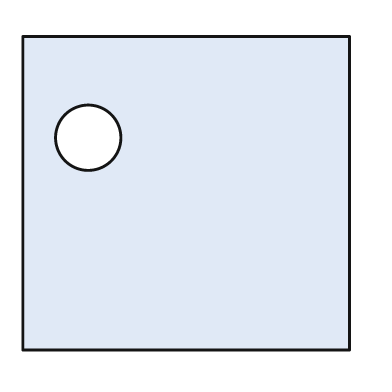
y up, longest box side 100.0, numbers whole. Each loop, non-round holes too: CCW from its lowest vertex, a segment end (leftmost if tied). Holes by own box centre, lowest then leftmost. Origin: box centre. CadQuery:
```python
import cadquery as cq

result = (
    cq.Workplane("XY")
    .moveTo(-50.0, -48.0)
    .lineTo(50.0, -48.0)
    .lineTo(50.0, 48.0)
    .lineTo(-50.0, 48.0)
    .close()
    .moveTo(-30.0, 17.0)
    .circle(10.0)
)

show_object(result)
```